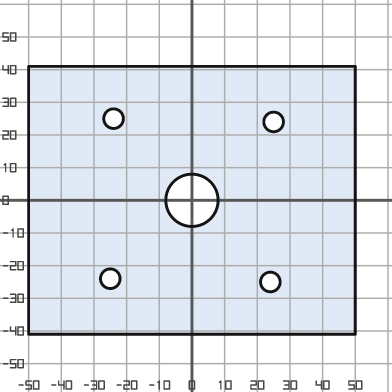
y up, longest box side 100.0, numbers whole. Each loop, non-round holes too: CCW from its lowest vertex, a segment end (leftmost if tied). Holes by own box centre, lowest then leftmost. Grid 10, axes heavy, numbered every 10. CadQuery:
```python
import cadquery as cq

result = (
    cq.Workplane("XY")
    .moveTo(-50.0, -41.0)
    .lineTo(50.0, -41.0)
    .lineTo(50.0, 41.0)
    .lineTo(-50.0, 41.0)
    .close()
    .moveTo(24.0, -25.0)
    .circle(3.0)
    .moveTo(-25.0, -24.0)
    .circle(3.0)
    .moveTo(0.0, 0.0)
    .circle(8.0)
    .moveTo(25.0, 24.0)
    .circle(3.0)
    .moveTo(-24.0, 25.0)
    .circle(3.0)
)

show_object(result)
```